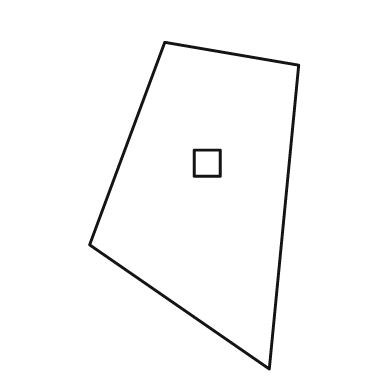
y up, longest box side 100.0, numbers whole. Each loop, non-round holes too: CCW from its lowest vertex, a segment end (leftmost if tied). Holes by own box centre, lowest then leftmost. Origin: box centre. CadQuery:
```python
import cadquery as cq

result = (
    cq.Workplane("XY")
    .moveTo(23.0, -50.0)
    .lineTo(32.0, 43.0)
    .lineTo(-9.0, 50.0)
    .lineTo(-32.0, -12.0)
    .close()
    .moveTo(0.0, 9.0)
    .lineTo(8.0, 9.0)
    .lineTo(8.0, 17.0)
    .lineTo(0.0, 17.0)
    .close()
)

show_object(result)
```